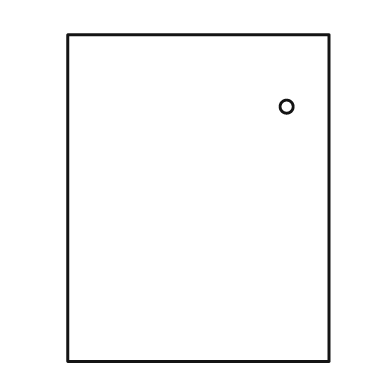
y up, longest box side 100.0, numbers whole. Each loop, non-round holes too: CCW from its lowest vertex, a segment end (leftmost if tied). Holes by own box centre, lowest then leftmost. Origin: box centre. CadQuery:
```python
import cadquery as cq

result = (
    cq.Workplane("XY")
    .moveTo(-40.0, -50.0)
    .lineTo(40.0, -50.0)
    .lineTo(40.0, 50.0)
    .lineTo(-40.0, 50.0)
    .close()
    .moveTo(27.0, 28.0)
    .circle(2.0)
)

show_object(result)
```